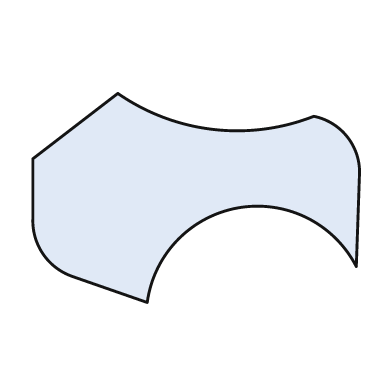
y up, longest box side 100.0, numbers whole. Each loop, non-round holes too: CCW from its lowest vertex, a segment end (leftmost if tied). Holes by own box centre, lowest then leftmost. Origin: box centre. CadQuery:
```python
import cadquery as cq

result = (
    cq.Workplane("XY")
    .moveTo(-15.0, -32.0)
    .threePointArc((13.0, -3.0), (49.0, -21.0))
    .lineTo(50.0, 8.0)
    .threePointArc((46.0, 19.0), (36.0, 25.0))
    .threePointArc((5.0, 21.0), (-24.0, 32.0))
    .lineTo(-50.0, 12.0)
    .lineTo(-50.0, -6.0)
    .threePointArc((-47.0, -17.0), (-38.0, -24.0))
    .close()
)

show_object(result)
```